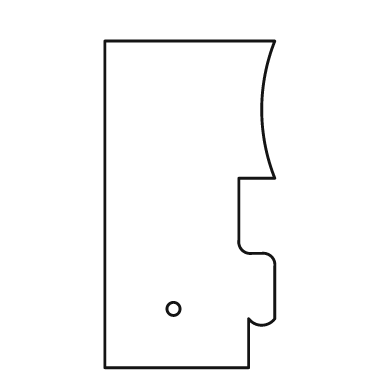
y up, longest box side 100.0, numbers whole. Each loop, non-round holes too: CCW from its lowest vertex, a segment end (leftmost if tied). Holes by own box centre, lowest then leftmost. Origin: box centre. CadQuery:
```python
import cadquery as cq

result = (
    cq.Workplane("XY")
    .moveTo(-26.0, -50.0)
    .lineTo(18.0, -50.0)
    .lineTo(18.0, -35.0)
    .threePointArc((22.0, -37.0), (26.0, -35.0))
    .lineTo(26.0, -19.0)
    .threePointArc((25.0, -16.0), (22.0, -15.0))
    .lineTo(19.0, -15.0)
    .threePointArc((16.0, -14.0), (15.0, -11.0))
    .lineTo(15.0, 8.0)
    .lineTo(26.0, 8.0)
    .threePointArc((22.0, 29.0), (26.0, 50.0))
    .lineTo(-26.0, 50.0)
    .close()
    .moveTo(-5.0, -32.0)
    .circle(2.0)
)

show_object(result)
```